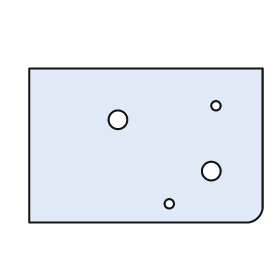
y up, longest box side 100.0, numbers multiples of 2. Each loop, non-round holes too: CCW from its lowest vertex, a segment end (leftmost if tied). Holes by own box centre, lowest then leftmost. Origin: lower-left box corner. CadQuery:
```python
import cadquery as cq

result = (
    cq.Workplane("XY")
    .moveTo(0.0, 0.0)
    .lineTo(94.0, 0.0)
    .threePointArc((98.0, 2.0), (100.0, 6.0))
    .lineTo(100.0, 66.0)
    .lineTo(0.0, 66.0)
    .close()
    .moveTo(60.0, 8.0)
    .circle(2.0)
    .moveTo(78.0, 22.0)
    .circle(4.0)
    .moveTo(38.0, 44.0)
    .circle(4.0)
    .moveTo(80.0, 50.0)
    .circle(2.0)
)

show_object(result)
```